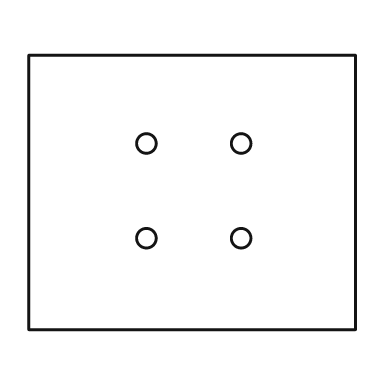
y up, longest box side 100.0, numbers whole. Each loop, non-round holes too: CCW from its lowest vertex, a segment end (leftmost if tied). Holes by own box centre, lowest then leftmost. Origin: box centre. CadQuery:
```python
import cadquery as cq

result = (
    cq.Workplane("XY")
    .moveTo(-50.0, -42.0)
    .lineTo(50.0, -42.0)
    .lineTo(50.0, 42.0)
    .lineTo(-50.0, 42.0)
    .close()
    .moveTo(-14.0, -14.0)
    .circle(3.0)
    .moveTo(15.0, -14.0)
    .circle(3.0)
    .moveTo(-14.0, 15.0)
    .circle(3.0)
    .moveTo(15.0, 15.0)
    .circle(3.0)
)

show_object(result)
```